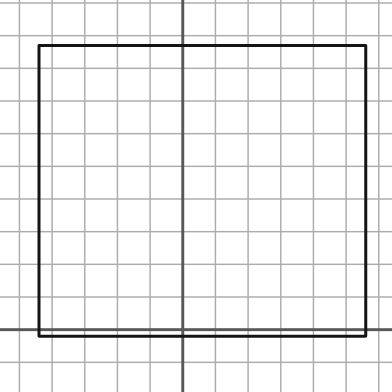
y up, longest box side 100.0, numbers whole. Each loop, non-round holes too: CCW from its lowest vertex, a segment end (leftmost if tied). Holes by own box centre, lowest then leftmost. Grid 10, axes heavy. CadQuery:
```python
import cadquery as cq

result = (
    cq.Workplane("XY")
    .moveTo(-44.0, -2.0)
    .lineTo(56.0, -2.0)
    .lineTo(56.0, 87.0)
    .lineTo(-44.0, 87.0)
    .close()
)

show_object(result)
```